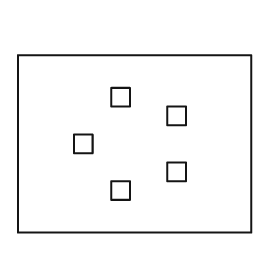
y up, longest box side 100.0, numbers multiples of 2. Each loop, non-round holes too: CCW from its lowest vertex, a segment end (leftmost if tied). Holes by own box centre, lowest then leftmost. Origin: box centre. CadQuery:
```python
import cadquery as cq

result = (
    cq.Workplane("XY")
    .moveTo(-50.0, -38.0)
    .lineTo(50.0, -38.0)
    .lineTo(50.0, 38.0)
    .lineTo(-50.0, 38.0)
    .close()
    .moveTo(-10.0, -24.0)
    .lineTo(-2.0, -24.0)
    .lineTo(-2.0, -16.0)
    .lineTo(-10.0, -16.0)
    .close()
    .moveTo(14.0, -16.0)
    .lineTo(22.0, -16.0)
    .lineTo(22.0, -8.0)
    .lineTo(14.0, -8.0)
    .close()
    .moveTo(-26.0, -4.0)
    .lineTo(-18.0, -4.0)
    .lineTo(-18.0, 4.0)
    .lineTo(-26.0, 4.0)
    .close()
    .moveTo(14.0, 8.0)
    .lineTo(22.0, 8.0)
    .lineTo(22.0, 16.0)
    .lineTo(14.0, 16.0)
    .close()
    .moveTo(-10.0, 16.0)
    .lineTo(-2.0, 16.0)
    .lineTo(-2.0, 24.0)
    .lineTo(-10.0, 24.0)
    .close()
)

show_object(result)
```